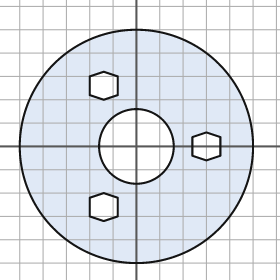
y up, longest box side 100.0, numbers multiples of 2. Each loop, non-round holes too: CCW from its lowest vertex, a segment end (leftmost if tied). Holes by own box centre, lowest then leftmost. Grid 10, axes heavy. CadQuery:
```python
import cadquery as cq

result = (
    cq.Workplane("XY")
    .moveTo(0.0, 0.0)
    .circle(50.0)
    .moveTo(-14.0, -32.0)
    .lineTo(-8.0, -30.0)
    .lineTo(-8.0, -22.0)
    .lineTo(-14.0, -20.0)
    .lineTo(-20.0, -22.0)
    .lineTo(-20.0, -30.0)
    .close()
    .moveTo(0.0, 0.0)
    .circle(16.0)
    .moveTo(30.0, -6.0)
    .lineTo(36.0, -4.0)
    .lineTo(36.0, 4.0)
    .lineTo(30.0, 6.0)
    .lineTo(24.0, 4.0)
    .lineTo(24.0, -4.0)
    .close()
    .moveTo(-14.0, 20.0)
    .lineTo(-8.0, 22.0)
    .lineTo(-8.0, 30.0)
    .lineTo(-14.0, 32.0)
    .lineTo(-20.0, 30.0)
    .lineTo(-20.0, 22.0)
    .close()
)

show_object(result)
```